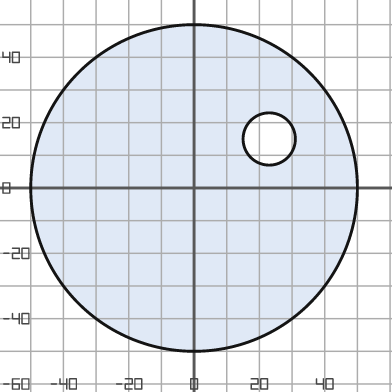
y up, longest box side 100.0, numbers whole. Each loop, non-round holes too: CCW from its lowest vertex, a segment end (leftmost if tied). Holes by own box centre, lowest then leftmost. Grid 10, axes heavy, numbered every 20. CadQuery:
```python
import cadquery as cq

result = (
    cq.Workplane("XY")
    .moveTo(0.0, 0.0)
    .circle(50.0)
    .moveTo(23.0, 15.0)
    .circle(8.0)
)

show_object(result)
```